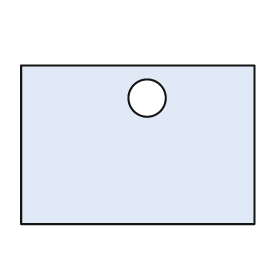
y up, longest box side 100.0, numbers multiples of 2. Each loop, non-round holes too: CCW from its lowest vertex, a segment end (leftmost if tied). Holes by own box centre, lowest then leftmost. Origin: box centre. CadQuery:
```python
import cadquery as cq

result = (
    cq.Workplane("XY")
    .moveTo(-50.0, -34.0)
    .lineTo(50.0, -34.0)
    .lineTo(50.0, 34.0)
    .lineTo(-50.0, 34.0)
    .close()
    .moveTo(4.0, 20.0)
    .circle(8.0)
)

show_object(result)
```